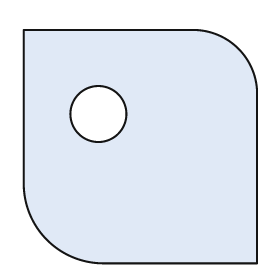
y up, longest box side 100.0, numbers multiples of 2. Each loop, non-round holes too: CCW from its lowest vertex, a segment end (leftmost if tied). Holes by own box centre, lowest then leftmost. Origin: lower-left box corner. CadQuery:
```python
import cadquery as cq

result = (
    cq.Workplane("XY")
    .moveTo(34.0, 0.0)
    .lineTo(100.0, 0.0)
    .lineTo(100.0, 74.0)
    .threePointArc((92.0, 92.0), (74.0, 100.0))
    .lineTo(0.0, 100.0)
    .lineTo(0.0, 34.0)
    .threePointArc((10.0, 10.0), (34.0, 0.0))
    .close()
    .moveTo(32.0, 64.0)
    .circle(12.0)
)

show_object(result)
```